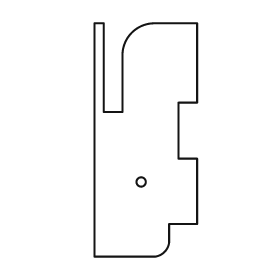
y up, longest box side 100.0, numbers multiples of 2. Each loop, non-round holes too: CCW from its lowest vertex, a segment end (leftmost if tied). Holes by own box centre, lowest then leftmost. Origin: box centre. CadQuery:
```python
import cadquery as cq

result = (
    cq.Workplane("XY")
    .moveTo(-22.0, -50.0)
    .lineTo(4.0, -50.0)
    .threePointArc((8.0, -48.0), (10.0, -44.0))
    .lineTo(10.0, -36.0)
    .lineTo(22.0, -36.0)
    .lineTo(22.0, -8.0)
    .lineTo(14.0, -8.0)
    .lineTo(14.0, 16.0)
    .lineTo(22.0, 16.0)
    .lineTo(22.0, 50.0)
    .lineTo(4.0, 50.0)
    .threePointArc((-6.0, 46.0), (-10.0, 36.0))
    .lineTo(-10.0, 12.0)
    .lineTo(-18.0, 12.0)
    .lineTo(-18.0, 50.0)
    .lineTo(-22.0, 50.0)
    .close()
    .moveTo(-2.0, -18.0)
    .circle(2.0)
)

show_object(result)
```